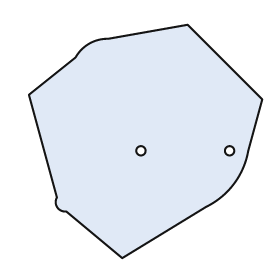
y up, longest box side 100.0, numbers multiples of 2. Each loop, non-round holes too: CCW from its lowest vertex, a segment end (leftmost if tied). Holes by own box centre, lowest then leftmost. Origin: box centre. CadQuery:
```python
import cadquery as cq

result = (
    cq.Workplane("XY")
    .moveTo(-10.0, -50.0)
    .lineTo(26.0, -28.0)
    .threePointArc((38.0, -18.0), (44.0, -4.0))
    .lineTo(50.0, 18.0)
    .lineTo(18.0, 50.0)
    .lineTo(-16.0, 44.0)
    .threePointArc((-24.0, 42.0), (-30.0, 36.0))
    .lineTo(-50.0, 20.0)
    .lineTo(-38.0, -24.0)
    .threePointArc((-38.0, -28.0), (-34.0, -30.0))
    .close()
    .moveTo(-2.0, -4.0)
    .circle(2.0)
    .moveTo(36.0, -4.0)
    .circle(2.0)
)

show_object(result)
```